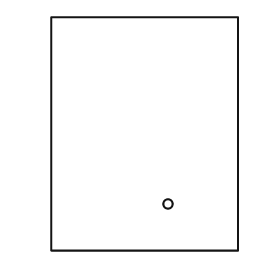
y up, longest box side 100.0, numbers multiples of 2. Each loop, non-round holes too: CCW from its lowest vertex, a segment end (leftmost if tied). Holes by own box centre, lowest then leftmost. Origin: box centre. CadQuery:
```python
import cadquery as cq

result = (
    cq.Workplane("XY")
    .moveTo(-40.0, -50.0)
    .lineTo(40.0, -50.0)
    .lineTo(40.0, 50.0)
    .lineTo(-40.0, 50.0)
    .close()
    .moveTo(10.0, -30.0)
    .circle(2.0)
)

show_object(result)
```